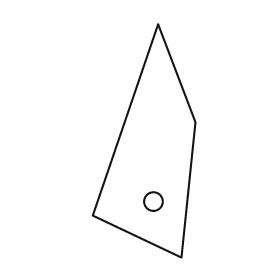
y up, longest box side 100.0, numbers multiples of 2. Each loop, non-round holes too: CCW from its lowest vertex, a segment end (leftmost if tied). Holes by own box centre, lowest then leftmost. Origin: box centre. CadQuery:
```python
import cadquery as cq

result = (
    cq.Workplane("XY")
    .moveTo(16.0, -50.0)
    .lineTo(22.0, 8.0)
    .lineTo(6.0, 50.0)
    .lineTo(-22.0, -32.0)
    .close()
    .moveTo(4.0, -26.0)
    .circle(4.0)
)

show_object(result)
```